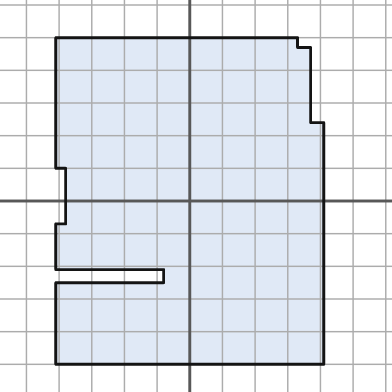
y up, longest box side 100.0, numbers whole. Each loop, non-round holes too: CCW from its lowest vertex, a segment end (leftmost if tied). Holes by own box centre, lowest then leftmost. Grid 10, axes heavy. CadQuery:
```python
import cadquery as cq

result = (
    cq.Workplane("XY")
    .moveTo(-41.0, -50.0)
    .lineTo(41.0, -50.0)
    .lineTo(41.0, 24.0)
    .lineTo(37.0, 24.0)
    .lineTo(37.0, 47.0)
    .lineTo(33.0, 47.0)
    .lineTo(33.0, 50.0)
    .lineTo(-41.0, 50.0)
    .lineTo(-41.0, 10.0)
    .lineTo(-38.0, 10.0)
    .lineTo(-38.0, -7.0)
    .lineTo(-41.0, -7.0)
    .lineTo(-41.0, -21.0)
    .lineTo(-8.0, -21.0)
    .lineTo(-8.0, -25.0)
    .lineTo(-41.0, -25.0)
    .close()
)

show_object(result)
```